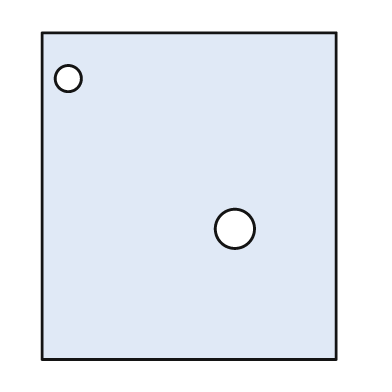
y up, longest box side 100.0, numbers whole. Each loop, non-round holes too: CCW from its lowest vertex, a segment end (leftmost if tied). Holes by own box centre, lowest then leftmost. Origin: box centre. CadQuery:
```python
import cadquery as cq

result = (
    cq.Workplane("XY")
    .moveTo(-45.0, -50.0)
    .lineTo(45.0, -50.0)
    .lineTo(45.0, 50.0)
    .lineTo(-45.0, 50.0)
    .close()
    .moveTo(14.0, -10.0)
    .circle(6.0)
    .moveTo(-37.0, 36.0)
    .circle(4.0)
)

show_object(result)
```